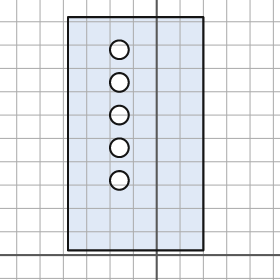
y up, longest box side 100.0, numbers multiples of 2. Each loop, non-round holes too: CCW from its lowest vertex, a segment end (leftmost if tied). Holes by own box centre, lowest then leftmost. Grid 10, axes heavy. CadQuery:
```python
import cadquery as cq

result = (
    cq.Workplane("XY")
    .moveTo(-38.0, 2.0)
    .lineTo(20.0, 2.0)
    .lineTo(20.0, 102.0)
    .lineTo(-38.0, 102.0)
    .close()
    .moveTo(-16.0, 32.0)
    .circle(4.0)
    .moveTo(-16.0, 46.0)
    .circle(4.0)
    .moveTo(-16.0, 60.0)
    .circle(4.0)
    .moveTo(-16.0, 74.0)
    .circle(4.0)
    .moveTo(-16.0, 88.0)
    .circle(4.0)
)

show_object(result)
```